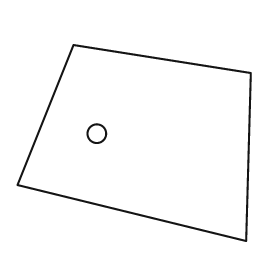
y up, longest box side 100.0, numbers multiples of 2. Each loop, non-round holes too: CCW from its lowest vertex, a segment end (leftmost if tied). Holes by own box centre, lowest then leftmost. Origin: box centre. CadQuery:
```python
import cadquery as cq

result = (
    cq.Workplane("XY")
    .moveTo(48.0, -42.0)
    .lineTo(50.0, 30.0)
    .lineTo(-26.0, 42.0)
    .lineTo(-50.0, -18.0)
    .close()
    .moveTo(-16.0, 4.0)
    .circle(4.0)
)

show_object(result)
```